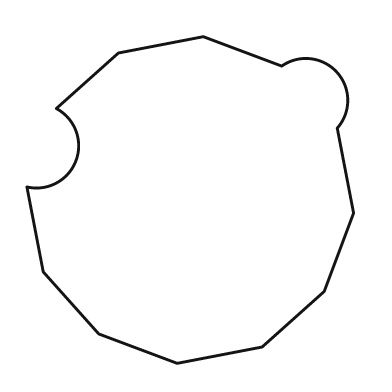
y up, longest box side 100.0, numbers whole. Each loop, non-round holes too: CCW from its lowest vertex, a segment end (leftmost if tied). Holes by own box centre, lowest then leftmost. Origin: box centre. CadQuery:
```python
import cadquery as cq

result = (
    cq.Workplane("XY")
    .moveTo(-4.0, -50.0)
    .lineTo(22.0, -45.0)
    .lineTo(41.0, -28.0)
    .lineTo(50.0, -4.0)
    .lineTo(45.0, 22.0)
    .threePointArc((45.0, 39.0), (28.0, 41.0))
    .lineTo(4.0, 50.0)
    .lineTo(-22.0, 45.0)
    .lineTo(-41.0, 28.0)
    .threePointArc((-35.0, 12.0), (-50.0, 4.0))
    .lineTo(-45.0, -22.0)
    .lineTo(-28.0, -41.0)
    .close()
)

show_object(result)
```